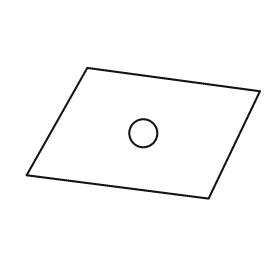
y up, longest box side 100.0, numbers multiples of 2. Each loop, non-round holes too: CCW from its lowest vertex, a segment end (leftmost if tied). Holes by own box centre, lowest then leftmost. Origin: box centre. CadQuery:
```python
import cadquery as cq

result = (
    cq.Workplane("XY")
    .moveTo(28.0, -28.0)
    .lineTo(50.0, 18.0)
    .lineTo(-24.0, 28.0)
    .lineTo(-50.0, -18.0)
    .close()
    .moveTo(0.0, 0.0)
    .circle(6.0)
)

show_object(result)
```